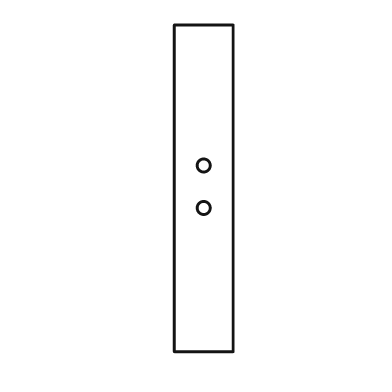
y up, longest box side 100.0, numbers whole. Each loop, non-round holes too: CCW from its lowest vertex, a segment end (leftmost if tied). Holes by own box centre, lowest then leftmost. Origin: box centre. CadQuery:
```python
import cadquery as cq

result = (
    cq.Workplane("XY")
    .moveTo(-9.0, -50.0)
    .lineTo(9.0, -50.0)
    .lineTo(9.0, 50.0)
    .lineTo(-9.0, 50.0)
    .close()
    .moveTo(0.0, -6.0)
    .circle(2.0)
    .moveTo(0.0, 7.0)
    .circle(2.0)
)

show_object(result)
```